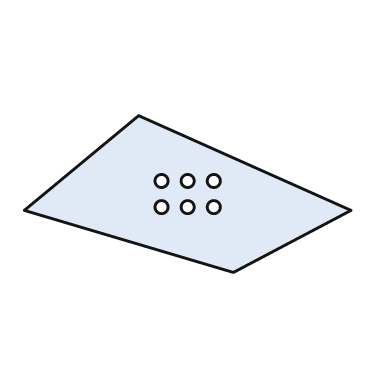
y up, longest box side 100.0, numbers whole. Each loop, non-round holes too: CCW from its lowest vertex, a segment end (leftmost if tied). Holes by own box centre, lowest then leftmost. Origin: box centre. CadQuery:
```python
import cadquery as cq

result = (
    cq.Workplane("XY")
    .moveTo(14.0, -24.0)
    .lineTo(50.0, -5.0)
    .lineTo(-15.0, 24.0)
    .lineTo(-50.0, -5.0)
    .close()
    .moveTo(-8.0, -4.0)
    .circle(2.0)
    .moveTo(0.0, -4.0)
    .circle(2.0)
    .moveTo(8.0, -4.0)
    .circle(2.0)
    .moveTo(-8.0, 4.0)
    .circle(2.0)
    .moveTo(0.0, 4.0)
    .circle(2.0)
    .moveTo(8.0, 4.0)
    .circle(2.0)
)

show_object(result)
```